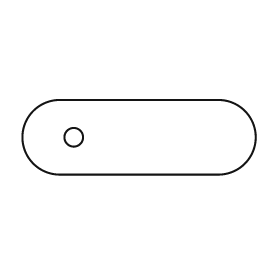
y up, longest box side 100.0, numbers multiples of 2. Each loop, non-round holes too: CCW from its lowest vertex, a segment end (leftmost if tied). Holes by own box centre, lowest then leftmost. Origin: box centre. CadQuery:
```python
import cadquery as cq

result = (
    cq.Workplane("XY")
    .moveTo(-34.0, -16.0)
    .lineTo(34.0, -16.0)
    .threePointArc((50.0, 0.0), (34.0, 16.0))
    .lineTo(-34.0, 16.0)
    .threePointArc((-50.0, 0.0), (-34.0, -16.0))
    .close()
    .moveTo(-28.0, 0.0)
    .circle(4.0)
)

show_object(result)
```